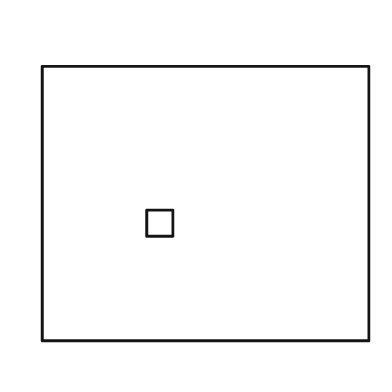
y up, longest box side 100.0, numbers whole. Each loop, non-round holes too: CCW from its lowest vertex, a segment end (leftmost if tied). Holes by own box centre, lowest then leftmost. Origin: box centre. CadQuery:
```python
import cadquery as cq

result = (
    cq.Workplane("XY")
    .moveTo(-50.0, -42.0)
    .lineTo(50.0, -42.0)
    .lineTo(50.0, 42.0)
    .lineTo(-50.0, 42.0)
    .close()
    .moveTo(-18.0, -10.0)
    .lineTo(-10.0, -10.0)
    .lineTo(-10.0, -2.0)
    .lineTo(-18.0, -2.0)
    .close()
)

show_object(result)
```